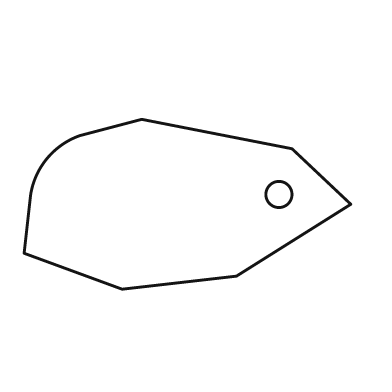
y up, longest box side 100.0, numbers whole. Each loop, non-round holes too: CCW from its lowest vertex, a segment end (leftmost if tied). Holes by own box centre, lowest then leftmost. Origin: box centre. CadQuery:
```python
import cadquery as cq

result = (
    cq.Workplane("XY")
    .moveTo(-20.0, -26.0)
    .lineTo(15.0, -22.0)
    .lineTo(50.0, 0.0)
    .lineTo(32.0, 17.0)
    .lineTo(-14.0, 26.0)
    .lineTo(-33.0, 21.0)
    .threePointArc((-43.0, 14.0), (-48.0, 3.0))
    .lineTo(-50.0, -15.0)
    .close()
    .moveTo(28.0, 3.0)
    .circle(4.0)
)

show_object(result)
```